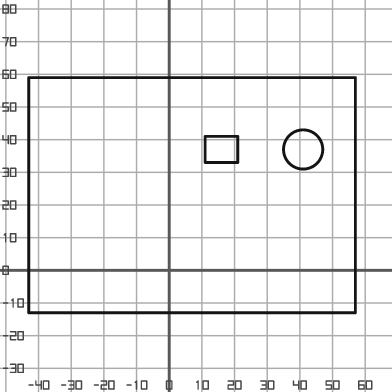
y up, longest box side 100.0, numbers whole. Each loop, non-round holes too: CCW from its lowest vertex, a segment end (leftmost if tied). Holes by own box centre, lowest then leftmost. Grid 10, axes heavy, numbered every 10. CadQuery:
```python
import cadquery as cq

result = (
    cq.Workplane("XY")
    .moveTo(-43.0, -13.0)
    .lineTo(57.0, -13.0)
    .lineTo(57.0, 59.0)
    .lineTo(-43.0, 59.0)
    .close()
    .moveTo(11.0, 33.0)
    .lineTo(21.0, 33.0)
    .lineTo(21.0, 41.0)
    .lineTo(11.0, 41.0)
    .close()
    .moveTo(41.0, 37.0)
    .circle(6.0)
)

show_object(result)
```